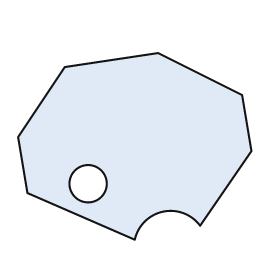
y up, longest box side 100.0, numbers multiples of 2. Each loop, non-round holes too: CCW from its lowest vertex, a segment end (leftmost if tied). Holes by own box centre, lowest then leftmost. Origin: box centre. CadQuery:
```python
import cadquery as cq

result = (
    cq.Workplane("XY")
    .moveTo(0.0, -40.0)
    .threePointArc((12.0, -28.0), (28.0, -34.0))
    .lineTo(50.0, -2.0)
    .lineTo(46.0, 22.0)
    .lineTo(10.0, 40.0)
    .lineTo(-30.0, 34.0)
    .lineTo(-50.0, 4.0)
    .lineTo(-46.0, -20.0)
    .close()
    .moveTo(-20.0, -16.0)
    .circle(8.0)
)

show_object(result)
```